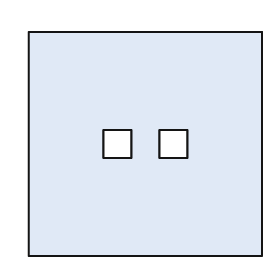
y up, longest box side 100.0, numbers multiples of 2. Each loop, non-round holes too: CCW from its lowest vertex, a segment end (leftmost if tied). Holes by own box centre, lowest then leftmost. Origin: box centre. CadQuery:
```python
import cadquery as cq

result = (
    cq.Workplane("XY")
    .moveTo(-50.0, -48.0)
    .lineTo(50.0, -48.0)
    .lineTo(50.0, 48.0)
    .lineTo(-50.0, 48.0)
    .close()
    .moveTo(-18.0, -6.0)
    .lineTo(-6.0, -6.0)
    .lineTo(-6.0, 6.0)
    .lineTo(-18.0, 6.0)
    .close()
    .moveTo(6.0, -6.0)
    .lineTo(18.0, -6.0)
    .lineTo(18.0, 6.0)
    .lineTo(6.0, 6.0)
    .close()
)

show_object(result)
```